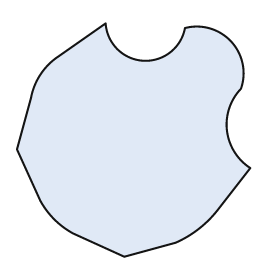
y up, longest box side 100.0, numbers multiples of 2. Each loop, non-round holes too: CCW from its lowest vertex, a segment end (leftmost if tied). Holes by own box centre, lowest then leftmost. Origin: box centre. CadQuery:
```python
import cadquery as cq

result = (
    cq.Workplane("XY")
    .moveTo(-4.0, -50.0)
    .lineTo(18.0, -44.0)
    .threePointArc((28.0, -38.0), (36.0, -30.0))
    .lineTo(50.0, -12.0)
    .threePointArc((40.0, 4.0), (46.0, 22.0))
    .threePointArc((42.0, 42.0), (22.0, 48.0))
    .threePointArc((4.0, 34.0), (-12.0, 50.0))
    .lineTo(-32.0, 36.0)
    .threePointArc((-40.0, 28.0), (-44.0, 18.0))
    .lineTo(-50.0, -4.0)
    .lineTo(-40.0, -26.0)
    .threePointArc((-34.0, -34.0), (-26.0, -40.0))
    .close()
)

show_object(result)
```